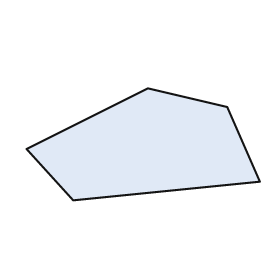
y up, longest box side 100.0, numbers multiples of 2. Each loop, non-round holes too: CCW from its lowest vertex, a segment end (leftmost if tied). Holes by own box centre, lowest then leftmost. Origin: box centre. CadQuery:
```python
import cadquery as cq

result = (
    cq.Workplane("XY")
    .moveTo(-30.0, -24.0)
    .lineTo(50.0, -16.0)
    .lineTo(36.0, 16.0)
    .lineTo(2.0, 24.0)
    .lineTo(-50.0, -2.0)
    .close()
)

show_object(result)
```